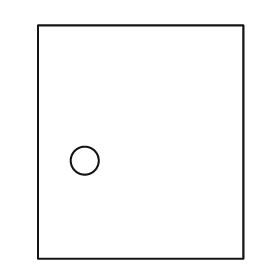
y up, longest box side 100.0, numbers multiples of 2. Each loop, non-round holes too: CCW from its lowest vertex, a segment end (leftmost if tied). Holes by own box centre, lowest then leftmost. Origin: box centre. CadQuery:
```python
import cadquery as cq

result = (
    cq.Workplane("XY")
    .moveTo(-44.0, -50.0)
    .lineTo(44.0, -50.0)
    .lineTo(44.0, 50.0)
    .lineTo(-44.0, 50.0)
    .close()
    .moveTo(-24.0, -8.0)
    .circle(6.0)
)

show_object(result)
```